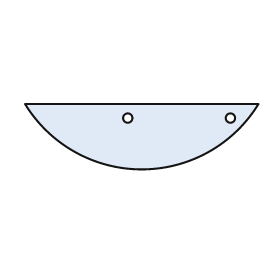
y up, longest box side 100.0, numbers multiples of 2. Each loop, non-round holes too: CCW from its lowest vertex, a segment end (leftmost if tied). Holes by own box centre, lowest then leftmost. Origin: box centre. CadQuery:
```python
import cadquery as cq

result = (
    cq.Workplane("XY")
    .moveTo(-50.0, 14.0)
    .threePointArc((0.0, -14.0), (50.0, 14.0))
    .close()
    .moveTo(-6.0, 8.0)
    .circle(2.0)
    .moveTo(38.0, 8.0)
    .circle(2.0)
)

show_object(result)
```